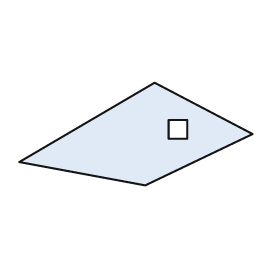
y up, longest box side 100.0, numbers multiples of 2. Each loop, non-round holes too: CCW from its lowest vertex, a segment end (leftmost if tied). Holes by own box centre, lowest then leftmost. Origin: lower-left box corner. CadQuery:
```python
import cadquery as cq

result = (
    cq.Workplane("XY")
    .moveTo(54.0, 0.0)
    .lineTo(100.0, 22.0)
    .lineTo(58.0, 44.0)
    .lineTo(0.0, 10.0)
    .close()
    .moveTo(64.0, 20.0)
    .lineTo(72.0, 20.0)
    .lineTo(72.0, 28.0)
    .lineTo(64.0, 28.0)
    .close()
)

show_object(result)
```